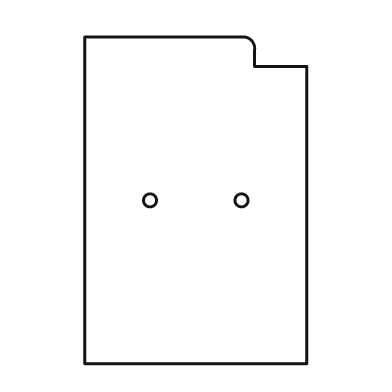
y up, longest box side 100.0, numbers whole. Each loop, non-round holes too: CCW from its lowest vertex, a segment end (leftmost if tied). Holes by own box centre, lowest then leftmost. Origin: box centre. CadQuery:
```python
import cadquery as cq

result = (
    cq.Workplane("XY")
    .moveTo(-34.0, -50.0)
    .lineTo(34.0, -50.0)
    .lineTo(34.0, 41.0)
    .lineTo(18.0, 41.0)
    .lineTo(18.0, 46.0)
    .threePointArc((17.0, 49.0), (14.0, 50.0))
    .lineTo(-34.0, 50.0)
    .close()
    .moveTo(-14.0, 0.0)
    .circle(2.0)
    .moveTo(14.0, 0.0)
    .circle(2.0)
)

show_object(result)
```